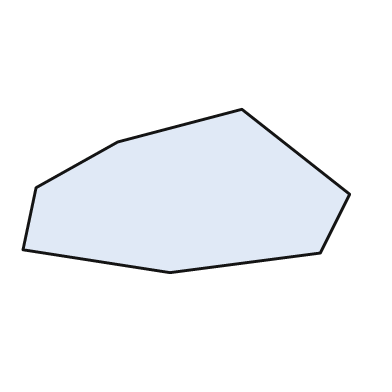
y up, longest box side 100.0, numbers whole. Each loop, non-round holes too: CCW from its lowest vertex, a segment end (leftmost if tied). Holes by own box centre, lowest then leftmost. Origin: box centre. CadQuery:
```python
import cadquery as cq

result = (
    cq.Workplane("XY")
    .moveTo(-5.0, -25.0)
    .lineTo(41.0, -19.0)
    .lineTo(50.0, -1.0)
    .lineTo(17.0, 25.0)
    .lineTo(-21.0, 15.0)
    .lineTo(-46.0, 1.0)
    .lineTo(-50.0, -18.0)
    .close()
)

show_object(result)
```